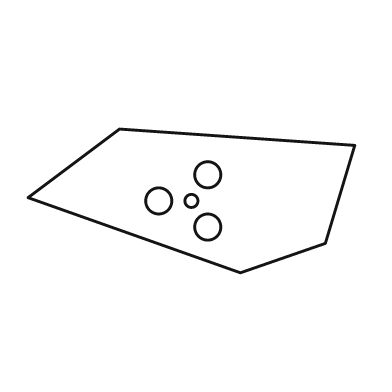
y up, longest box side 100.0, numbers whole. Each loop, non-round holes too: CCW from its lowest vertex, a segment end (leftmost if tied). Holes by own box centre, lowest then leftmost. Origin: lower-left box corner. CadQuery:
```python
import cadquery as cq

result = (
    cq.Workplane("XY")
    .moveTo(65.0, 0.0)
    .lineTo(91.0, 9.0)
    .lineTo(100.0, 39.0)
    .lineTo(28.0, 44.0)
    .lineTo(0.0, 23.0)
    .close()
    .moveTo(55.0, 14.0)
    .circle(4.0)
    .moveTo(40.0, 22.0)
    .circle(4.0)
    .moveTo(50.0, 22.0)
    .circle(2.0)
    .moveTo(55.0, 30.0)
    .circle(4.0)
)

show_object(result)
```